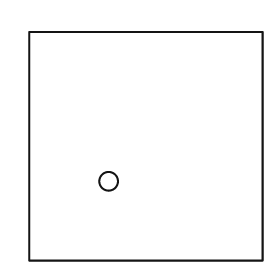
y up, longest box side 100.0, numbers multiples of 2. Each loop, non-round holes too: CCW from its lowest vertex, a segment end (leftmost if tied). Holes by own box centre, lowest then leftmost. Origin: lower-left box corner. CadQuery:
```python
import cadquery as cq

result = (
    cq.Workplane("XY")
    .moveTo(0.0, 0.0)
    .lineTo(100.0, 0.0)
    .lineTo(100.0, 98.0)
    .lineTo(0.0, 98.0)
    .close()
    .moveTo(34.0, 34.0)
    .circle(4.0)
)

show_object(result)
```